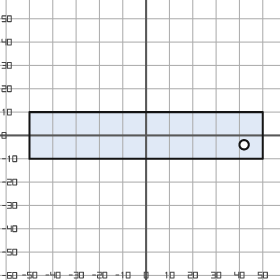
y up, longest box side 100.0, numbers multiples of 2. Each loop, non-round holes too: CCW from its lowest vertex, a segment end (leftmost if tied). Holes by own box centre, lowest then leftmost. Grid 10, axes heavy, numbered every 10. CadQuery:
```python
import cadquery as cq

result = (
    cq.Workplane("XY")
    .moveTo(-50.0, -10.0)
    .lineTo(50.0, -10.0)
    .lineTo(50.0, 10.0)
    .lineTo(-50.0, 10.0)
    .close()
    .moveTo(42.0, -4.0)
    .circle(2.0)
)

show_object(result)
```